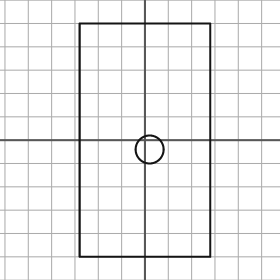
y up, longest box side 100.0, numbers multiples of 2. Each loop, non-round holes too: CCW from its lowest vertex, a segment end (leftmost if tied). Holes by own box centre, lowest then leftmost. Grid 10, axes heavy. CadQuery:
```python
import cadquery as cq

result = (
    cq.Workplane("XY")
    .moveTo(-28.0, -50.0)
    .lineTo(28.0, -50.0)
    .lineTo(28.0, 50.0)
    .lineTo(-28.0, 50.0)
    .close()
    .moveTo(2.0, -4.0)
    .circle(6.0)
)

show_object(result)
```